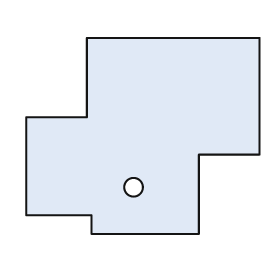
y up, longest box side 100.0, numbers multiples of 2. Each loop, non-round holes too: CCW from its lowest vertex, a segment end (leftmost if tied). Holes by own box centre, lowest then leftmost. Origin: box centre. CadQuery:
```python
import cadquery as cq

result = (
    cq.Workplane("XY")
    .moveTo(-22.0, -42.0)
    .lineTo(24.0, -42.0)
    .lineTo(24.0, -8.0)
    .lineTo(50.0, -8.0)
    .lineTo(50.0, 42.0)
    .lineTo(-24.0, 42.0)
    .lineTo(-24.0, 8.0)
    .lineTo(-50.0, 8.0)
    .lineTo(-50.0, -34.0)
    .lineTo(-22.0, -34.0)
    .close()
    .moveTo(-4.0, -22.0)
    .circle(4.0)
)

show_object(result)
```